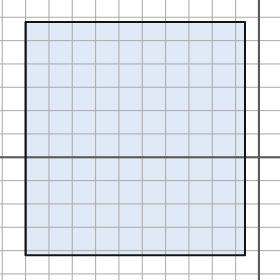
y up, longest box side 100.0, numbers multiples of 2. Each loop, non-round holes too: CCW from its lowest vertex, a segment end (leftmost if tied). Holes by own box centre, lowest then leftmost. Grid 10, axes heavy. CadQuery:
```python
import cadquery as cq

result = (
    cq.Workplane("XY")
    .moveTo(-100.0, -42.0)
    .lineTo(-6.0, -42.0)
    .lineTo(-6.0, 58.0)
    .lineTo(-100.0, 58.0)
    .close()
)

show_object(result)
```